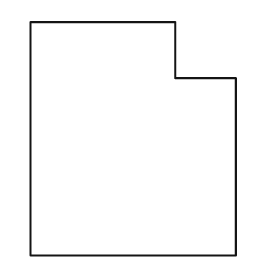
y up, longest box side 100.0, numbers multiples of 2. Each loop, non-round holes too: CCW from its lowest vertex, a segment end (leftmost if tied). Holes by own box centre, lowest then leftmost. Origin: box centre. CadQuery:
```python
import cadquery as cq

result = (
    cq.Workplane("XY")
    .moveTo(-44.0, -50.0)
    .lineTo(44.0, -50.0)
    .lineTo(44.0, 26.0)
    .lineTo(18.0, 26.0)
    .lineTo(18.0, 50.0)
    .lineTo(-44.0, 50.0)
    .close()
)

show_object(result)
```